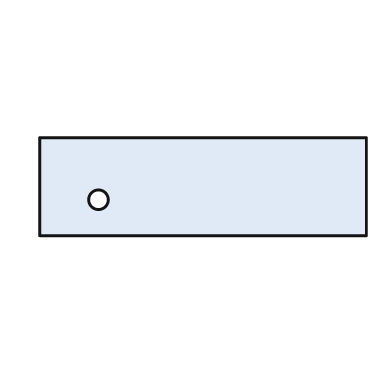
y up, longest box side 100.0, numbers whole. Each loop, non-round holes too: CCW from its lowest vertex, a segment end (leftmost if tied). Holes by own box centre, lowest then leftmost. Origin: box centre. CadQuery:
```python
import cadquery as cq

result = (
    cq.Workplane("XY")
    .moveTo(-50.0, -15.0)
    .lineTo(50.0, -15.0)
    .lineTo(50.0, 15.0)
    .lineTo(-50.0, 15.0)
    .close()
    .moveTo(-32.0, -4.0)
    .circle(3.0)
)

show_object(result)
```